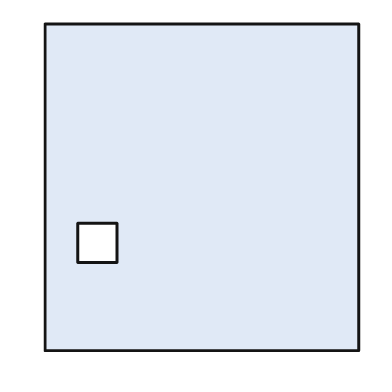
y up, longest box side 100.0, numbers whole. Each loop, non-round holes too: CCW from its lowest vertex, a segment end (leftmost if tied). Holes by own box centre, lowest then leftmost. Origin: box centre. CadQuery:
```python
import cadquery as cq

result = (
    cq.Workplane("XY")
    .moveTo(-48.0, -50.0)
    .lineTo(48.0, -50.0)
    .lineTo(48.0, 50.0)
    .lineTo(-48.0, 50.0)
    .close()
    .moveTo(-38.0, -23.0)
    .lineTo(-26.0, -23.0)
    .lineTo(-26.0, -11.0)
    .lineTo(-38.0, -11.0)
    .close()
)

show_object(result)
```